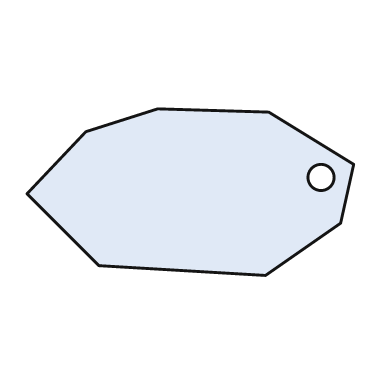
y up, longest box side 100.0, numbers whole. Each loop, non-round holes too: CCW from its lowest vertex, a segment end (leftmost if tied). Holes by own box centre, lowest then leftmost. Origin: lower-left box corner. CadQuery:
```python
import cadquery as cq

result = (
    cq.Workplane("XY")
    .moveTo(73.0, 0.0)
    .lineTo(96.0, 16.0)
    .lineTo(100.0, 34.0)
    .lineTo(74.0, 50.0)
    .lineTo(40.0, 51.0)
    .lineTo(18.0, 44.0)
    .lineTo(0.0, 25.0)
    .lineTo(22.0, 3.0)
    .close()
    .moveTo(90.0, 30.0)
    .circle(4.0)
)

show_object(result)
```